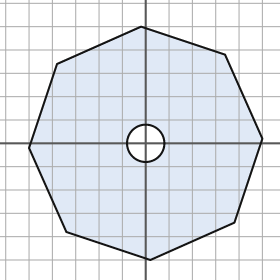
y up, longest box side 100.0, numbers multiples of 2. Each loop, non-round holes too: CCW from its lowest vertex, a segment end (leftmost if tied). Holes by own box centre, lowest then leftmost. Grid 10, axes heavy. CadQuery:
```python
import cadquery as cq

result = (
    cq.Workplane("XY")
    .moveTo(2.0, -50.0)
    .lineTo(38.0, -34.0)
    .lineTo(50.0, 2.0)
    .lineTo(34.0, 38.0)
    .lineTo(-2.0, 50.0)
    .lineTo(-38.0, 34.0)
    .lineTo(-50.0, -2.0)
    .lineTo(-34.0, -38.0)
    .close()
    .moveTo(0.0, 0.0)
    .circle(8.0)
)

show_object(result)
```